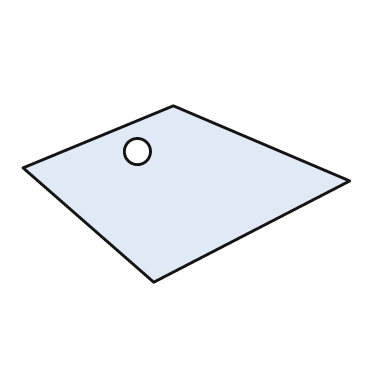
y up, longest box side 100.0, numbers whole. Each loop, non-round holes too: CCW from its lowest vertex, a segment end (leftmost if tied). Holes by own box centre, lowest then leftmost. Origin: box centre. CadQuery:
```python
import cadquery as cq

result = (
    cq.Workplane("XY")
    .moveTo(-10.0, -27.0)
    .lineTo(50.0, 4.0)
    .lineTo(-4.0, 27.0)
    .lineTo(-50.0, 8.0)
    .close()
    .moveTo(-15.0, 13.0)
    .circle(4.0)
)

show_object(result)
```